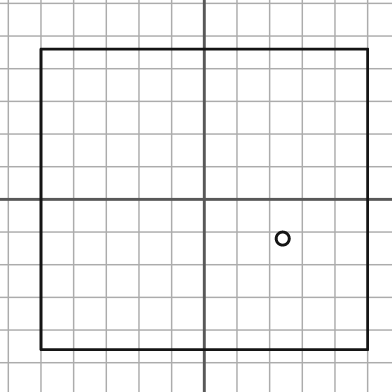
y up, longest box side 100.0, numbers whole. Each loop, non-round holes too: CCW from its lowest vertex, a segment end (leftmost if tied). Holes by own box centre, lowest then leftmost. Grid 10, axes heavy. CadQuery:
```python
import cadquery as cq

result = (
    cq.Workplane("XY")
    .moveTo(-50.0, -46.0)
    .lineTo(50.0, -46.0)
    .lineTo(50.0, 46.0)
    .lineTo(-50.0, 46.0)
    .close()
    .moveTo(24.0, -12.0)
    .circle(2.0)
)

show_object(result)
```